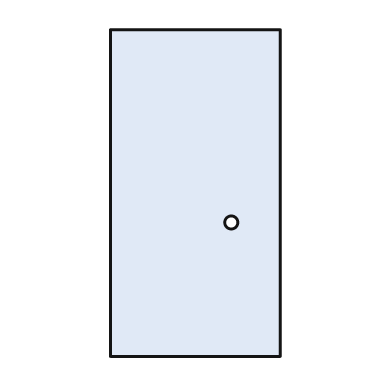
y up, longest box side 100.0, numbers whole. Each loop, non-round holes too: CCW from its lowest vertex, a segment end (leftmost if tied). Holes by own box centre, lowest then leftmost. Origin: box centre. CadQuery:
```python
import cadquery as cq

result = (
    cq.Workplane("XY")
    .moveTo(-26.0, -50.0)
    .lineTo(26.0, -50.0)
    .lineTo(26.0, 50.0)
    .lineTo(-26.0, 50.0)
    .close()
    .moveTo(11.0, -9.0)
    .circle(2.0)
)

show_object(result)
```